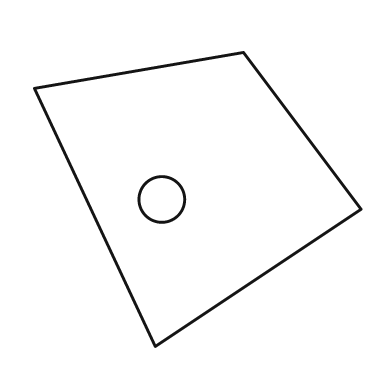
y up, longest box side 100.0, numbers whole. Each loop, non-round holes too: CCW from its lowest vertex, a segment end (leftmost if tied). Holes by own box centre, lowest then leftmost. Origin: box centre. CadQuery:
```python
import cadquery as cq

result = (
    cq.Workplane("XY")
    .moveTo(-13.0, -45.0)
    .lineTo(50.0, -3.0)
    .lineTo(14.0, 45.0)
    .lineTo(-50.0, 34.0)
    .close()
    .moveTo(-11.0, 0.0)
    .circle(7.0)
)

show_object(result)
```